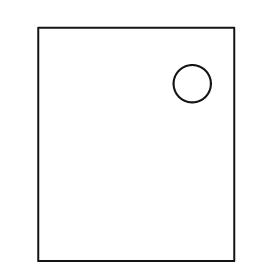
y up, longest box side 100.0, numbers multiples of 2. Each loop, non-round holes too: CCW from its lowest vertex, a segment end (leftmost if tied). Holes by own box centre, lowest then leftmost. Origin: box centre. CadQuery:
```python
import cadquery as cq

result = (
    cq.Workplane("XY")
    .moveTo(-42.0, -50.0)
    .lineTo(42.0, -50.0)
    .lineTo(42.0, 50.0)
    .lineTo(-42.0, 50.0)
    .close()
    .moveTo(24.0, 26.0)
    .circle(8.0)
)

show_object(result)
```